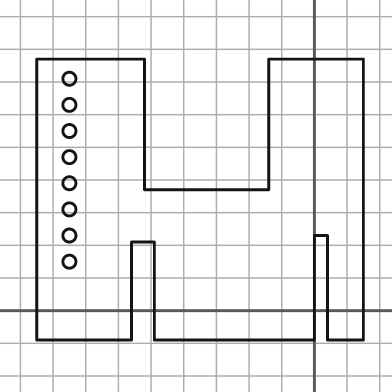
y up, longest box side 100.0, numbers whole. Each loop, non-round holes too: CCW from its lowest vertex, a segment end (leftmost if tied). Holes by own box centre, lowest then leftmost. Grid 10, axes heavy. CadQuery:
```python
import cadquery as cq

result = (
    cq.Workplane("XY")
    .moveTo(-85.0, -9.0)
    .lineTo(-56.0, -9.0)
    .lineTo(-56.0, 21.0)
    .lineTo(-49.0, 21.0)
    .lineTo(-49.0, -9.0)
    .lineTo(0.0, -9.0)
    .lineTo(0.0, 23.0)
    .lineTo(4.0, 23.0)
    .lineTo(4.0, -9.0)
    .lineTo(15.0, -9.0)
    .lineTo(15.0, 77.0)
    .lineTo(-14.0, 77.0)
    .lineTo(-14.0, 37.0)
    .lineTo(-52.0, 37.0)
    .lineTo(-52.0, 77.0)
    .lineTo(-85.0, 77.0)
    .close()
    .moveTo(-75.0, 15.0)
    .circle(2.0)
    .moveTo(-75.0, 23.0)
    .circle(2.0)
    .moveTo(-75.0, 31.0)
    .circle(2.0)
    .moveTo(-75.0, 39.0)
    .circle(2.0)
    .moveTo(-75.0, 47.0)
    .circle(2.0)
    .moveTo(-75.0, 55.0)
    .circle(2.0)
    .moveTo(-75.0, 63.0)
    .circle(2.0)
    .moveTo(-75.0, 71.0)
    .circle(2.0)
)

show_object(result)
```